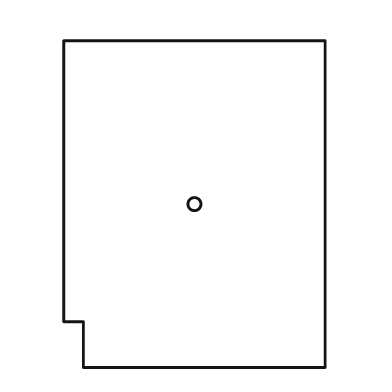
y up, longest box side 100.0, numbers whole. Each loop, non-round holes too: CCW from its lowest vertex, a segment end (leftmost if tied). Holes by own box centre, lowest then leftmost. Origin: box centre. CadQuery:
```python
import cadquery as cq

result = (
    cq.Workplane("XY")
    .moveTo(-34.0, -50.0)
    .lineTo(40.0, -50.0)
    .lineTo(40.0, 50.0)
    .lineTo(-40.0, 50.0)
    .lineTo(-40.0, -36.0)
    .lineTo(-34.0, -36.0)
    .close()
    .moveTo(0.0, 0.0)
    .circle(2.0)
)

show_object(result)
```